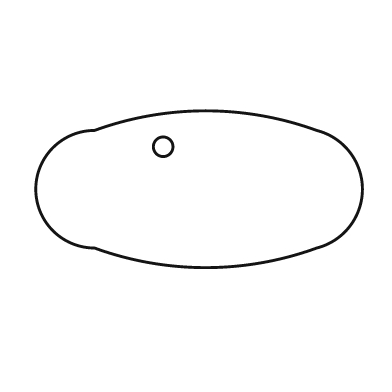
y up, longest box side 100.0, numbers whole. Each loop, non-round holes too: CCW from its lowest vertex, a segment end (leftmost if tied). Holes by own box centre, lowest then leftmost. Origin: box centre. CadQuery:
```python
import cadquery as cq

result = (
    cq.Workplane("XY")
    .moveTo(-32.0, -18.0)
    .threePointArc((2.0, -24.0), (36.0, -18.0))
    .threePointArc((50.0, 0.0), (36.0, 18.0))
    .threePointArc((2.0, 24.0), (-32.0, 18.0))
    .threePointArc((-50.0, 0.0), (-32.0, -18.0))
    .close()
    .moveTo(-11.0, 13.0)
    .circle(3.0)
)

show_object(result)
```